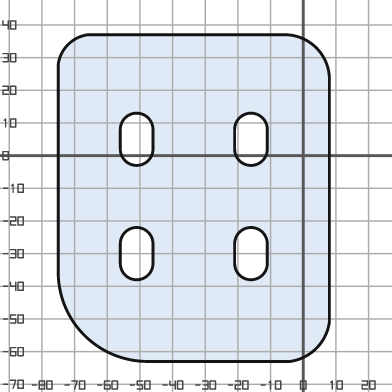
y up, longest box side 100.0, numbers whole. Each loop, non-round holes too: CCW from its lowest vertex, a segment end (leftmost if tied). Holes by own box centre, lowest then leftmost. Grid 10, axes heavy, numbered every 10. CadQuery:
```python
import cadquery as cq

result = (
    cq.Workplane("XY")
    .moveTo(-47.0, -63.0)
    .lineTo(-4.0, -63.0)
    .threePointArc((4.0, -59.0), (8.0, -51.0))
    .lineTo(8.0, 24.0)
    .threePointArc((4.0, 33.0), (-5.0, 37.0))
    .lineTo(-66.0, 37.0)
    .threePointArc((-72.0, 34.0), (-75.0, 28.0))
    .lineTo(-75.0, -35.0)
    .threePointArc((-67.0, -55.0), (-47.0, -63.0))
    .close()
    .moveTo(-56.0, -33.0)
    .threePointArc((-51.0, -38.0), (-46.0, -33.0))
    .lineTo(-46.0, -27.0)
    .threePointArc((-51.0, -22.0), (-56.0, -27.0))
    .close()
    .moveTo(-21.0, -33.0)
    .threePointArc((-16.0, -38.0), (-11.0, -33.0))
    .lineTo(-11.0, -27.0)
    .threePointArc((-16.0, -22.0), (-21.0, -27.0))
    .close()
    .moveTo(-56.0, 2.0)
    .threePointArc((-51.0, -3.0), (-46.0, 2.0))
    .lineTo(-46.0, 8.0)
    .threePointArc((-51.0, 13.0), (-56.0, 8.0))
    .close()
    .moveTo(-21.0, 2.0)
    .threePointArc((-16.0, -3.0), (-11.0, 2.0))
    .lineTo(-11.0, 8.0)
    .threePointArc((-16.0, 13.0), (-21.0, 8.0))
    .close()
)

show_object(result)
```